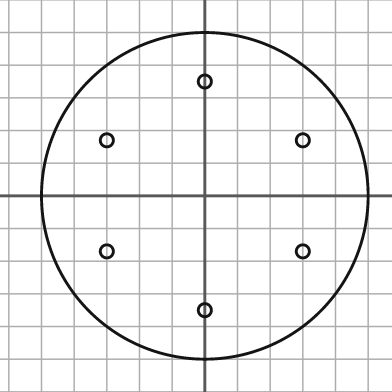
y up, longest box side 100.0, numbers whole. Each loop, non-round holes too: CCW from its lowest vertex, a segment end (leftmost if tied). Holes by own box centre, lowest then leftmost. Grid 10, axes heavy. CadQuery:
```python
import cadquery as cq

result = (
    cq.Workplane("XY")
    .moveTo(0.0, 0.0)
    .circle(50.0)
    .moveTo(0.0, -35.0)
    .circle(2.0)
    .moveTo(-30.0, -17.0)
    .circle(2.0)
    .moveTo(30.0, -17.0)
    .circle(2.0)
    .moveTo(-30.0, 17.0)
    .circle(2.0)
    .moveTo(30.0, 17.0)
    .circle(2.0)
    .moveTo(0.0, 35.0)
    .circle(2.0)
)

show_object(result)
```